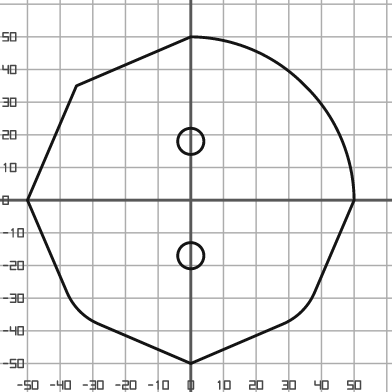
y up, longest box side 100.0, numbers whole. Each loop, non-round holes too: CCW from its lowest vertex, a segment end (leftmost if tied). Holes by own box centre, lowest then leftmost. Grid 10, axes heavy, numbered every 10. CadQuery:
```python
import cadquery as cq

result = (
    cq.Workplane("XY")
    .moveTo(0.0, -50.0)
    .lineTo(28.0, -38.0)
    .threePointArc((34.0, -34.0), (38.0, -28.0))
    .lineTo(50.0, 0.0)
    .threePointArc((46.0, 19.0), (35.0, 35.0))
    .threePointArc((19.0, 46.0), (0.0, 50.0))
    .lineTo(-35.0, 35.0)
    .lineTo(-50.0, 0.0)
    .lineTo(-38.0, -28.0)
    .threePointArc((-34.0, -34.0), (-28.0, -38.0))
    .close()
    .moveTo(0.0, -17.0)
    .circle(4.0)
    .moveTo(0.0, 18.0)
    .circle(4.0)
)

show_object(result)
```